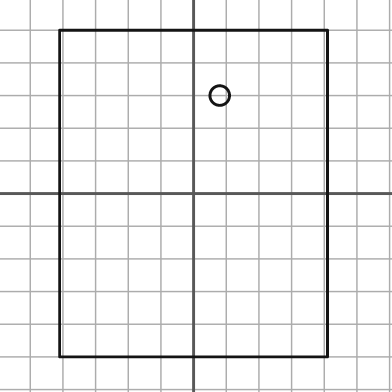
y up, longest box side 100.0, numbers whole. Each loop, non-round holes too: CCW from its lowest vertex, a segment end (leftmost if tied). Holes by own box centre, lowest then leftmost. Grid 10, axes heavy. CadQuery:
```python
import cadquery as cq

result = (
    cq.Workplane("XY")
    .moveTo(-41.0, -50.0)
    .lineTo(41.0, -50.0)
    .lineTo(41.0, 50.0)
    .lineTo(-41.0, 50.0)
    .close()
    .moveTo(8.0, 30.0)
    .circle(3.0)
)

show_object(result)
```